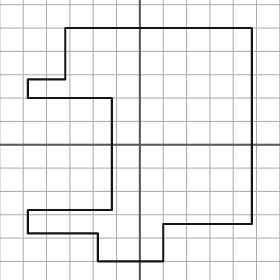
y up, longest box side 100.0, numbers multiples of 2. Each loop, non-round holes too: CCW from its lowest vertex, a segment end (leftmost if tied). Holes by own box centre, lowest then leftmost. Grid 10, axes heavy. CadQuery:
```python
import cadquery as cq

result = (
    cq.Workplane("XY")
    .moveTo(-18.0, -50.0)
    .lineTo(10.0, -50.0)
    .lineTo(10.0, -34.0)
    .lineTo(48.0, -34.0)
    .lineTo(48.0, 50.0)
    .lineTo(-32.0, 50.0)
    .lineTo(-32.0, 28.0)
    .lineTo(-48.0, 28.0)
    .lineTo(-48.0, 20.0)
    .lineTo(-12.0, 20.0)
    .lineTo(-12.0, -28.0)
    .lineTo(-48.0, -28.0)
    .lineTo(-48.0, -38.0)
    .lineTo(-18.0, -38.0)
    .close()
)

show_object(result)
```